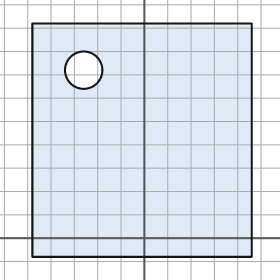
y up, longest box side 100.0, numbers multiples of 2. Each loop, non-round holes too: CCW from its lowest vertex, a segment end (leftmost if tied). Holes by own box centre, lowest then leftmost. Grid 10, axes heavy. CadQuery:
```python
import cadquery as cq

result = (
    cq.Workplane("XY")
    .moveTo(-48.0, -8.0)
    .lineTo(46.0, -8.0)
    .lineTo(46.0, 92.0)
    .lineTo(-48.0, 92.0)
    .close()
    .moveTo(-26.0, 72.0)
    .circle(8.0)
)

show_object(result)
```